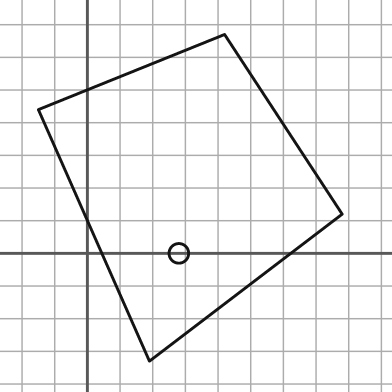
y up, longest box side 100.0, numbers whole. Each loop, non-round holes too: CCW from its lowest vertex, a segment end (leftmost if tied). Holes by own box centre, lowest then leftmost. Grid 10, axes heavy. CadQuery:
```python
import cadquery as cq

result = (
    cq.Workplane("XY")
    .moveTo(19.0, -33.0)
    .lineTo(78.0, 12.0)
    .lineTo(42.0, 67.0)
    .lineTo(-15.0, 44.0)
    .close()
    .moveTo(28.0, 0.0)
    .circle(3.0)
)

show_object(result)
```